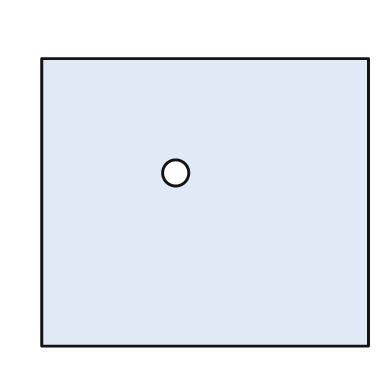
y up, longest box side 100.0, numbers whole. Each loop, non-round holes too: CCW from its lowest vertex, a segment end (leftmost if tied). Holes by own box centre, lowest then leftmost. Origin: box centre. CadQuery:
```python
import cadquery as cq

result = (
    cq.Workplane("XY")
    .moveTo(-50.0, -44.0)
    .lineTo(50.0, -44.0)
    .lineTo(50.0, 44.0)
    .lineTo(-50.0, 44.0)
    .close()
    .moveTo(-9.0, 9.0)
    .circle(4.0)
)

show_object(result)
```